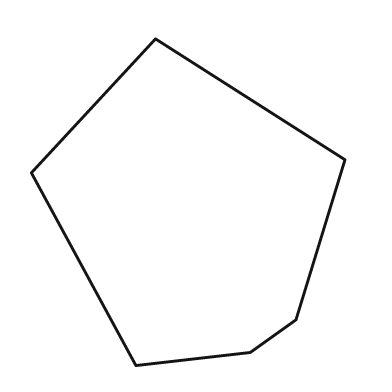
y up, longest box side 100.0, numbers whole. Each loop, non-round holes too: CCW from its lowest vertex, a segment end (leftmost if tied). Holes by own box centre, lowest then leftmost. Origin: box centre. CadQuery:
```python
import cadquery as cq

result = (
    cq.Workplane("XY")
    .moveTo(-16.0, -50.0)
    .lineTo(19.0, -46.0)
    .lineTo(33.0, -36.0)
    .lineTo(48.0, 13.0)
    .lineTo(-10.0, 50.0)
    .lineTo(-48.0, 9.0)
    .close()
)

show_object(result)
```